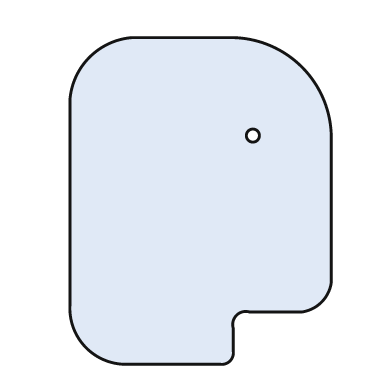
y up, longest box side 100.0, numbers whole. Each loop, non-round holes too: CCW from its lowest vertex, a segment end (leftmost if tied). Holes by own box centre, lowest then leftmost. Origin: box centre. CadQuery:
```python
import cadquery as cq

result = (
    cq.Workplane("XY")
    .moveTo(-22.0, -50.0)
    .lineTo(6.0, -50.0)
    .threePointArc((9.0, -49.0), (10.0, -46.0))
    .lineTo(10.0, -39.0)
    .threePointArc((11.0, -35.0), (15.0, -34.0))
    .lineTo(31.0, -34.0)
    .threePointArc((37.0, -31.0), (40.0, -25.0))
    .lineTo(40.0, 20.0)
    .threePointArc((31.0, 41.0), (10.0, 50.0))
    .lineTo(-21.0, 50.0)
    .threePointArc((-34.0, 44.0), (-40.0, 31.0))
    .lineTo(-40.0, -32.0)
    .threePointArc((-35.0, -45.0), (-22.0, -50.0))
    .close()
    .moveTo(16.0, 20.0)
    .circle(2.0)
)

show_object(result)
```